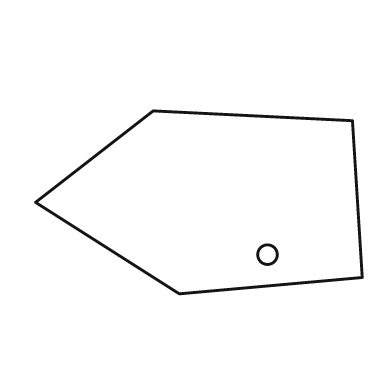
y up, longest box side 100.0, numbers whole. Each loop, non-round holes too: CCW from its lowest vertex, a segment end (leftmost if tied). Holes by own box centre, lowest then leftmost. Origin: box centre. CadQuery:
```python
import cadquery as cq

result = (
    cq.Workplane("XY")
    .moveTo(-6.0, -28.0)
    .lineTo(50.0, -23.0)
    .lineTo(47.0, 25.0)
    .lineTo(-14.0, 28.0)
    .lineTo(-50.0, 0.0)
    .close()
    .moveTo(21.0, -16.0)
    .circle(3.0)
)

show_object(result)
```